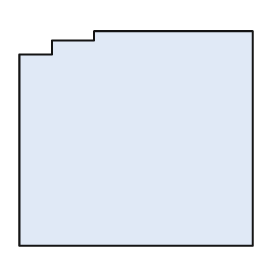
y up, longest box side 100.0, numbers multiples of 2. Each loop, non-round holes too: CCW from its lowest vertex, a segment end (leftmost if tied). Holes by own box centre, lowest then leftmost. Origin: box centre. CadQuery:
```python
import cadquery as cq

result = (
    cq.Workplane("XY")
    .moveTo(-50.0, -46.0)
    .lineTo(50.0, -46.0)
    .lineTo(50.0, 46.0)
    .lineTo(-18.0, 46.0)
    .lineTo(-18.0, 42.0)
    .lineTo(-36.0, 42.0)
    .lineTo(-36.0, 36.0)
    .lineTo(-50.0, 36.0)
    .close()
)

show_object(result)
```